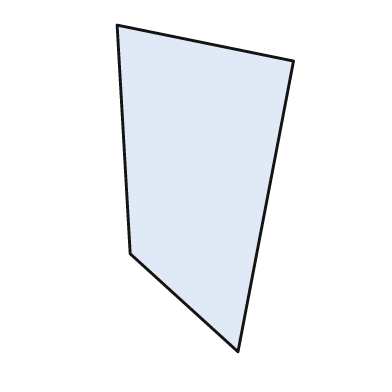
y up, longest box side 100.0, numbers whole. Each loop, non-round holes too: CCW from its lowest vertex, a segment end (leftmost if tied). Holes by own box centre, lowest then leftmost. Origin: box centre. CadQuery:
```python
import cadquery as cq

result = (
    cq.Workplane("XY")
    .moveTo(10.0, -50.0)
    .lineTo(27.0, 39.0)
    .lineTo(-27.0, 50.0)
    .lineTo(-23.0, -20.0)
    .close()
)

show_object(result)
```